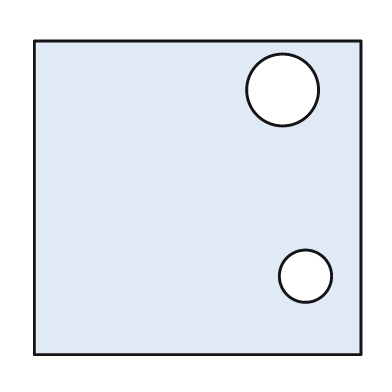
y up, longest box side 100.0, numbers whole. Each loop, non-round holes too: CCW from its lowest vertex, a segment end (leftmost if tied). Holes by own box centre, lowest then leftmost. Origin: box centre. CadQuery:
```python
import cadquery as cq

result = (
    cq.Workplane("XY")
    .moveTo(-50.0, -48.0)
    .lineTo(50.0, -48.0)
    .lineTo(50.0, 48.0)
    .lineTo(-50.0, 48.0)
    .close()
    .moveTo(33.0, -24.0)
    .circle(8.0)
    .moveTo(26.0, 33.0)
    .circle(11.0)
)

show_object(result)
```